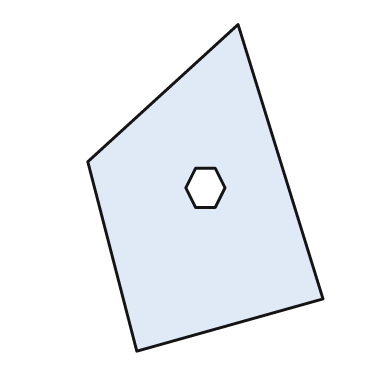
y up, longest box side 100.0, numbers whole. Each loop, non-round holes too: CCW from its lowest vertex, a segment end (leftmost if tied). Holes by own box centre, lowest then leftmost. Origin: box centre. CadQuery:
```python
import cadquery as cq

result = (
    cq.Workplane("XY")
    .moveTo(-21.0, -50.0)
    .lineTo(36.0, -34.0)
    .lineTo(10.0, 50.0)
    .lineTo(-36.0, 8.0)
    .close()
    .moveTo(-3.0, -6.0)
    .lineTo(3.0, -6.0)
    .lineTo(6.0, 0.0)
    .lineTo(3.0, 6.0)
    .lineTo(-3.0, 6.0)
    .lineTo(-6.0, 0.0)
    .close()
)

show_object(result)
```